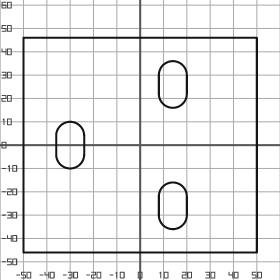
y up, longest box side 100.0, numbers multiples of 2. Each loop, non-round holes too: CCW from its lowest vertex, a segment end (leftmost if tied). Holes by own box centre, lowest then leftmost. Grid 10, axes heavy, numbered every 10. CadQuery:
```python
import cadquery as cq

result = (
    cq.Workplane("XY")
    .moveTo(-50.0, -46.0)
    .lineTo(50.0, -46.0)
    .lineTo(50.0, 46.0)
    .lineTo(-50.0, 46.0)
    .close()
    .moveTo(8.0, -30.0)
    .threePointArc((14.0, -36.0), (20.0, -30.0))
    .lineTo(20.0, -22.0)
    .threePointArc((14.0, -16.0), (8.0, -22.0))
    .close()
    .moveTo(-36.0, -4.0)
    .threePointArc((-30.0, -10.0), (-24.0, -4.0))
    .lineTo(-24.0, 4.0)
    .threePointArc((-30.0, 10.0), (-36.0, 4.0))
    .close()
    .moveTo(8.0, 22.0)
    .threePointArc((14.0, 16.0), (20.0, 22.0))
    .lineTo(20.0, 30.0)
    .threePointArc((14.0, 36.0), (8.0, 30.0))
    .close()
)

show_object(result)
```